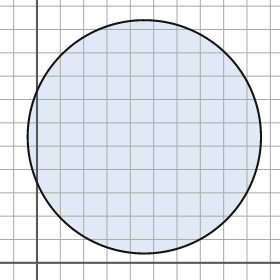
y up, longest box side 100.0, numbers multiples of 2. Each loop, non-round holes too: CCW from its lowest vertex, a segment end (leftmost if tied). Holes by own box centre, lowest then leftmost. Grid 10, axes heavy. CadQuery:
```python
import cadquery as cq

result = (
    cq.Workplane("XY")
    .moveTo(46.0, 54.0)
    .circle(50.0)
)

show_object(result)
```